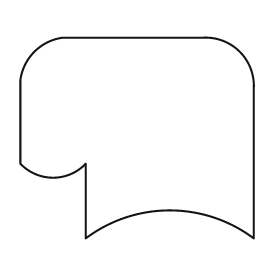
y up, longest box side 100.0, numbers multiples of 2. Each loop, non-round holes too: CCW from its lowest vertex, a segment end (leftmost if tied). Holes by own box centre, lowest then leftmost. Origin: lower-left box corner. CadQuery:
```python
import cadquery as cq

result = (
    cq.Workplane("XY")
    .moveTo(28.0, 0.0)
    .threePointArc((64.0, 12.0), (100.0, 0.0))
    .lineTo(100.0, 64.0)
    .threePointArc((94.0, 80.0), (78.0, 86.0))
    .lineTo(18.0, 86.0)
    .threePointArc((6.0, 80.0), (0.0, 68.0))
    .lineTo(0.0, 32.0)
    .threePointArc((14.0, 26.0), (28.0, 32.0))
    .close()
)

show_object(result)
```